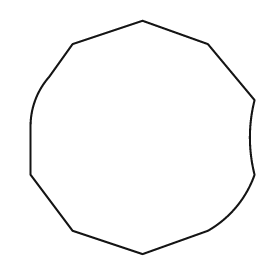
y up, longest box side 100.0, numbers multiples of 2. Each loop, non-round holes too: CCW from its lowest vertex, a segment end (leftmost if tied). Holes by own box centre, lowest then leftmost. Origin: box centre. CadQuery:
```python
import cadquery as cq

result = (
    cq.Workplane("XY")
    .moveTo(0.0, -50.0)
    .lineTo(28.0, -40.0)
    .threePointArc((40.0, -30.0), (48.0, -16.0))
    .threePointArc((46.0, 0.0), (48.0, 16.0))
    .lineTo(28.0, 40.0)
    .lineTo(0.0, 50.0)
    .lineTo(-30.0, 40.0)
    .lineTo(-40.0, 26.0)
    .threePointArc((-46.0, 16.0), (-48.0, 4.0))
    .lineTo(-48.0, -16.0)
    .lineTo(-30.0, -40.0)
    .close()
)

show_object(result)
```